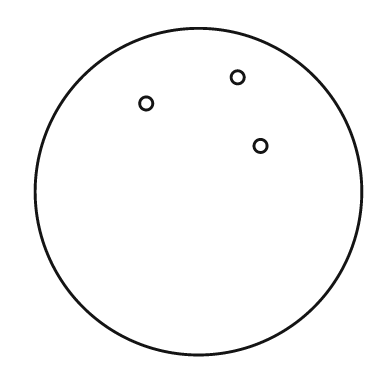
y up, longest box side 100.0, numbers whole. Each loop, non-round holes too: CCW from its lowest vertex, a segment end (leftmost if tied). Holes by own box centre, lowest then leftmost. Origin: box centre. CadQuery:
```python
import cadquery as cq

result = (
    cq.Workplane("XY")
    .moveTo(0.0, 0.0)
    .circle(50.0)
    .moveTo(19.0, 14.0)
    .circle(2.0)
    .moveTo(-16.0, 27.0)
    .circle(2.0)
    .moveTo(12.0, 35.0)
    .circle(2.0)
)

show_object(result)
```